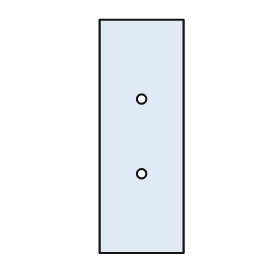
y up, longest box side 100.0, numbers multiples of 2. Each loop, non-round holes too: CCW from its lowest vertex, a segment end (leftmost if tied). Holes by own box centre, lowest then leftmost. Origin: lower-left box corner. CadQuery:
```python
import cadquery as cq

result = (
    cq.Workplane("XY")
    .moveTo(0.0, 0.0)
    .lineTo(36.0, 0.0)
    .lineTo(36.0, 100.0)
    .lineTo(0.0, 100.0)
    .close()
    .moveTo(18.0, 34.0)
    .circle(2.0)
    .moveTo(18.0, 66.0)
    .circle(2.0)
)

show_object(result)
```